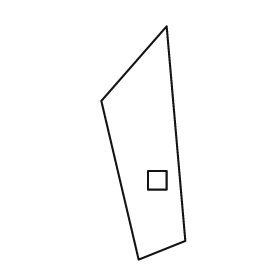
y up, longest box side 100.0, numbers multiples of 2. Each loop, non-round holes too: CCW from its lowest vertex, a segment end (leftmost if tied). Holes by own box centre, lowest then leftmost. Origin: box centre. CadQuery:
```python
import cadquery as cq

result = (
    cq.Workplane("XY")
    .moveTo(-2.0, -50.0)
    .lineTo(18.0, -42.0)
    .lineTo(10.0, 50.0)
    .lineTo(-18.0, 18.0)
    .close()
    .moveTo(2.0, -20.0)
    .lineTo(10.0, -20.0)
    .lineTo(10.0, -12.0)
    .lineTo(2.0, -12.0)
    .close()
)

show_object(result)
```